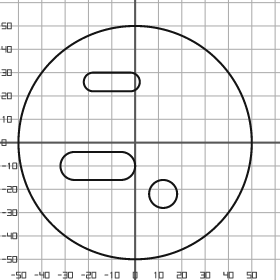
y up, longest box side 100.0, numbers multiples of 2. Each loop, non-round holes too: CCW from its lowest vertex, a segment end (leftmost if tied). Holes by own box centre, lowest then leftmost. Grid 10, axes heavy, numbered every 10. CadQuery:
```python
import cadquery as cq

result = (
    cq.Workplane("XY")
    .moveTo(0.0, 0.0)
    .circle(50.0)
    .moveTo(12.0, -22.0)
    .circle(6.0)
    .moveTo(-26.0, -16.0)
    .lineTo(-6.0, -16.0)
    .threePointArc((0.0, -10.0), (-6.0, -4.0))
    .lineTo(-26.0, -4.0)
    .threePointArc((-32.0, -10.0), (-26.0, -16.0))
    .close()
    .moveTo(-18.0, 22.0)
    .lineTo(-2.0, 22.0)
    .threePointArc((2.0, 26.0), (-2.0, 30.0))
    .lineTo(-18.0, 30.0)
    .threePointArc((-22.0, 26.0), (-18.0, 22.0))
    .close()
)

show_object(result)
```